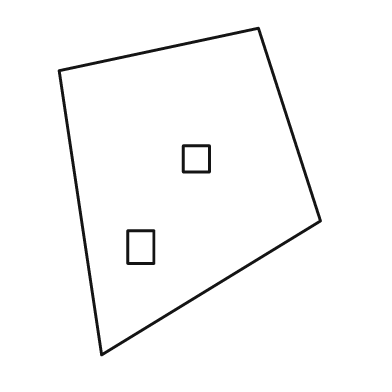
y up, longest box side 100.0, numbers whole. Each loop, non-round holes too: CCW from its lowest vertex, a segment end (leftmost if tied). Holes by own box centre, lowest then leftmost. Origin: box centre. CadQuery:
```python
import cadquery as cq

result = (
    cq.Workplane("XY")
    .moveTo(-27.0, -50.0)
    .lineTo(40.0, -9.0)
    .lineTo(21.0, 50.0)
    .lineTo(-40.0, 37.0)
    .close()
    .moveTo(-19.0, -22.0)
    .lineTo(-11.0, -22.0)
    .lineTo(-11.0, -12.0)
    .lineTo(-19.0, -12.0)
    .close()
    .moveTo(-2.0, 6.0)
    .lineTo(6.0, 6.0)
    .lineTo(6.0, 14.0)
    .lineTo(-2.0, 14.0)
    .close()
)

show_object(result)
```